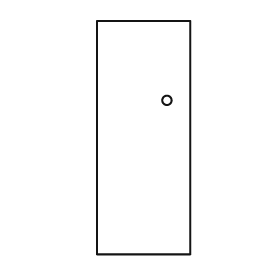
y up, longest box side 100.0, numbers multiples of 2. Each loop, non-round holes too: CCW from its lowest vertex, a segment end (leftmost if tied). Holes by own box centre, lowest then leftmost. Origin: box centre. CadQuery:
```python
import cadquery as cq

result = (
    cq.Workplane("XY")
    .moveTo(-20.0, -50.0)
    .lineTo(20.0, -50.0)
    .lineTo(20.0, 50.0)
    .lineTo(-20.0, 50.0)
    .close()
    .moveTo(10.0, 16.0)
    .circle(2.0)
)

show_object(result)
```